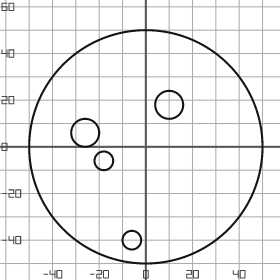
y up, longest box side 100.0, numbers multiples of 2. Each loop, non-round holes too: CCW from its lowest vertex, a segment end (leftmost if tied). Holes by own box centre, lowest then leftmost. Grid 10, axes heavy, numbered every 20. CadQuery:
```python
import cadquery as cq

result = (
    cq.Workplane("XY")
    .moveTo(0.0, 0.0)
    .circle(50.0)
    .moveTo(-6.0, -40.0)
    .circle(4.0)
    .moveTo(-18.0, -6.0)
    .circle(4.0)
    .moveTo(-26.0, 6.0)
    .circle(6.0)
    .moveTo(10.0, 18.0)
    .circle(6.0)
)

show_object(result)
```